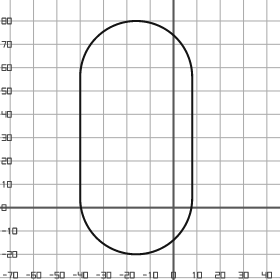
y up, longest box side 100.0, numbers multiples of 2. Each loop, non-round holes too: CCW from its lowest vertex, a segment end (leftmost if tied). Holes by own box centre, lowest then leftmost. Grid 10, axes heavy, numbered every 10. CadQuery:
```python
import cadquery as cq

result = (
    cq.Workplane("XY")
    .moveTo(-40.0, 4.0)
    .threePointArc((-16.0, -20.0), (8.0, 4.0))
    .lineTo(8.0, 56.0)
    .threePointArc((-16.0, 80.0), (-40.0, 56.0))
    .close()
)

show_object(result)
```